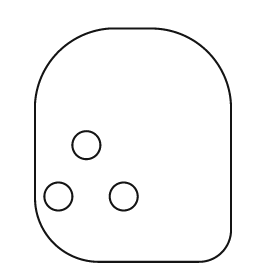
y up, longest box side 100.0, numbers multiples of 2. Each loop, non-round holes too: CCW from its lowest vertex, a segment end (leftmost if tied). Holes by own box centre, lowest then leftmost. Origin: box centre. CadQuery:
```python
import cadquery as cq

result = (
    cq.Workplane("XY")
    .moveTo(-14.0, -50.0)
    .lineTo(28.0, -50.0)
    .threePointArc((38.0, -46.0), (42.0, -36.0))
    .lineTo(42.0, 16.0)
    .threePointArc((32.0, 40.0), (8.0, 50.0))
    .lineTo(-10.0, 50.0)
    .threePointArc((-32.0, 40.0), (-42.0, 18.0))
    .lineTo(-42.0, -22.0)
    .threePointArc((-34.0, -42.0), (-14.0, -50.0))
    .close()
    .moveTo(-32.0, -22.0)
    .circle(6.0)
    .moveTo(-4.0, -22.0)
    .circle(6.0)
    .moveTo(-20.0, 0.0)
    .circle(6.0)
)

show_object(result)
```